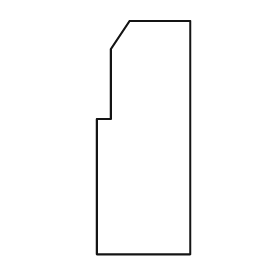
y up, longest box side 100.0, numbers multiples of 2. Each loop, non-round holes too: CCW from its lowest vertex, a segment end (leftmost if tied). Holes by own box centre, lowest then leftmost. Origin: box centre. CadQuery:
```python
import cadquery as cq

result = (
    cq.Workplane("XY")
    .moveTo(-20.0, -50.0)
    .lineTo(20.0, -50.0)
    .lineTo(20.0, 50.0)
    .lineTo(-6.0, 50.0)
    .lineTo(-14.0, 38.0)
    .lineTo(-14.0, 8.0)
    .lineTo(-20.0, 8.0)
    .close()
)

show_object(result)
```